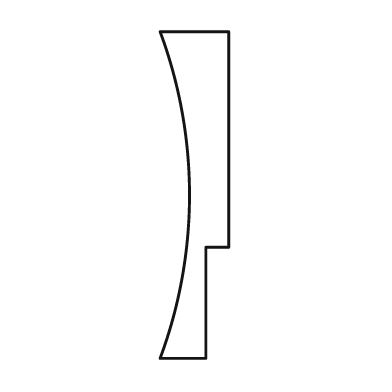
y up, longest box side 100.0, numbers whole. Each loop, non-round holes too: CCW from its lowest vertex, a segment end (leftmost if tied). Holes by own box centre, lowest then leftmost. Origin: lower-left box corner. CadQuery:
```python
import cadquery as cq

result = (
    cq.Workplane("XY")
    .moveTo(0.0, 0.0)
    .lineTo(14.0, 0.0)
    .lineTo(14.0, 34.0)
    .lineTo(21.0, 34.0)
    .lineTo(21.0, 100.0)
    .lineTo(0.0, 100.0)
    .threePointArc((9.0, 50.0), (0.0, 0.0))
    .close()
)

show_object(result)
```